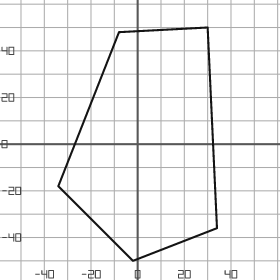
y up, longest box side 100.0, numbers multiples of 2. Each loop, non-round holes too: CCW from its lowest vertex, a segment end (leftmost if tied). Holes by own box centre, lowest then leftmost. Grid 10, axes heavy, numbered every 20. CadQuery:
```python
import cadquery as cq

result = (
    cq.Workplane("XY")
    .moveTo(-2.0, -50.0)
    .lineTo(34.0, -36.0)
    .lineTo(30.0, 50.0)
    .lineTo(-8.0, 48.0)
    .lineTo(-34.0, -18.0)
    .close()
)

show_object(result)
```